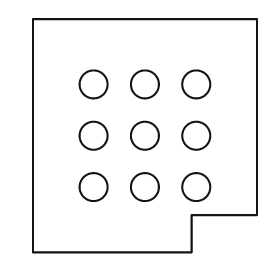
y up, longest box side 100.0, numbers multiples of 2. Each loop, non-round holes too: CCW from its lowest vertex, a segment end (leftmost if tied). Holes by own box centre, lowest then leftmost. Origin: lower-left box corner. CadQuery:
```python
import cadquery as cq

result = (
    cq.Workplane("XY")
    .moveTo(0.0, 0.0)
    .lineTo(68.0, 0.0)
    .lineTo(68.0, 16.0)
    .lineTo(96.0, 16.0)
    .lineTo(96.0, 100.0)
    .lineTo(0.0, 100.0)
    .close()
    .moveTo(26.0, 28.0)
    .circle(6.0)
    .moveTo(48.0, 28.0)
    .circle(6.0)
    .moveTo(70.0, 28.0)
    .circle(6.0)
    .moveTo(26.0, 50.0)
    .circle(6.0)
    .moveTo(48.0, 50.0)
    .circle(6.0)
    .moveTo(70.0, 50.0)
    .circle(6.0)
    .moveTo(26.0, 72.0)
    .circle(6.0)
    .moveTo(48.0, 72.0)
    .circle(6.0)
    .moveTo(70.0, 72.0)
    .circle(6.0)
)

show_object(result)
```